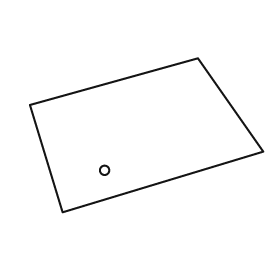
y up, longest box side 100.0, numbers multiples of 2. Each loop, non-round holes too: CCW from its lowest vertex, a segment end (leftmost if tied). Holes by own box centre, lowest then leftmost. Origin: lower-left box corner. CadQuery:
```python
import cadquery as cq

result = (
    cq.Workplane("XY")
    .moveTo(14.0, 0.0)
    .lineTo(100.0, 26.0)
    .lineTo(72.0, 66.0)
    .lineTo(0.0, 46.0)
    .close()
    .moveTo(32.0, 18.0)
    .circle(2.0)
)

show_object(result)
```